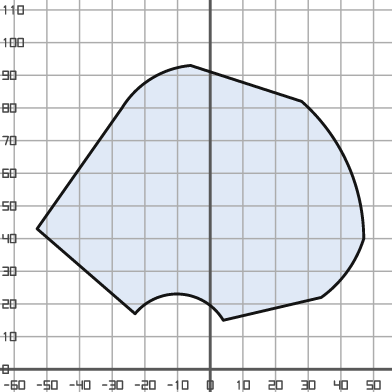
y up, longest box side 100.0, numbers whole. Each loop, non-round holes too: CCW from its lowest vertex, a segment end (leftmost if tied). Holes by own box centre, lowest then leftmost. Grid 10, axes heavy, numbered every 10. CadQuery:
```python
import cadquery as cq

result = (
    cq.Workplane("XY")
    .moveTo(4.0, 15.0)
    .lineTo(34.0, 22.0)
    .threePointArc((42.0, 30.0), (47.0, 40.0))
    .threePointArc((42.0, 63.0), (28.0, 82.0))
    .lineTo(-6.0, 93.0)
    .threePointArc((-18.0, 89.0), (-27.0, 80.0))
    .lineTo(-53.0, 43.0)
    .lineTo(-23.0, 17.0)
    .threePointArc((-9.0, 23.0), (4.0, 15.0))
    .close()
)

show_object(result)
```